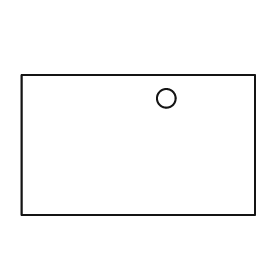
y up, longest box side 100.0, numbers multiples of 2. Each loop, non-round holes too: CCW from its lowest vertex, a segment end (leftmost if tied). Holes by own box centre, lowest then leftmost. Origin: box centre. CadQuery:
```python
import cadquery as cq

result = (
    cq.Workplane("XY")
    .moveTo(-50.0, -30.0)
    .lineTo(50.0, -30.0)
    .lineTo(50.0, 30.0)
    .lineTo(-50.0, 30.0)
    .close()
    .moveTo(12.0, 20.0)
    .circle(4.0)
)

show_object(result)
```